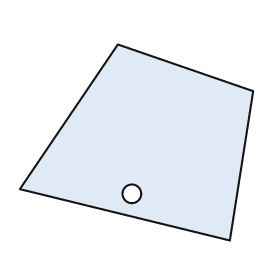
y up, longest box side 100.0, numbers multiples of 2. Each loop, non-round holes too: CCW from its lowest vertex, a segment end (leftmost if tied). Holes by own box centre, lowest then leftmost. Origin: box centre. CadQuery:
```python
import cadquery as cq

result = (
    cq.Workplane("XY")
    .moveTo(40.0, -42.0)
    .lineTo(50.0, 22.0)
    .lineTo(-8.0, 42.0)
    .lineTo(-50.0, -20.0)
    .close()
    .moveTo(-2.0, -22.0)
    .circle(4.0)
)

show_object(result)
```